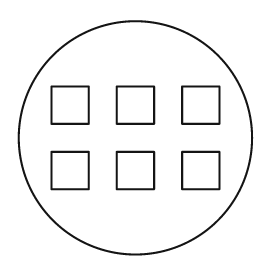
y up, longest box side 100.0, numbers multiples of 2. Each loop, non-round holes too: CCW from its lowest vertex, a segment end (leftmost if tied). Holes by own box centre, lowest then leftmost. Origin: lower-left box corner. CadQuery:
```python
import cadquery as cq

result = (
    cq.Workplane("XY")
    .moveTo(50.0, 50.0)
    .circle(50.0)
    .moveTo(14.0, 28.0)
    .lineTo(30.0, 28.0)
    .lineTo(30.0, 44.0)
    .lineTo(14.0, 44.0)
    .close()
    .moveTo(42.0, 28.0)
    .lineTo(58.0, 28.0)
    .lineTo(58.0, 44.0)
    .lineTo(42.0, 44.0)
    .close()
    .moveTo(70.0, 28.0)
    .lineTo(86.0, 28.0)
    .lineTo(86.0, 44.0)
    .lineTo(70.0, 44.0)
    .close()
    .moveTo(14.0, 56.0)
    .lineTo(30.0, 56.0)
    .lineTo(30.0, 72.0)
    .lineTo(14.0, 72.0)
    .close()
    .moveTo(42.0, 56.0)
    .lineTo(58.0, 56.0)
    .lineTo(58.0, 72.0)
    .lineTo(42.0, 72.0)
    .close()
    .moveTo(70.0, 56.0)
    .lineTo(86.0, 56.0)
    .lineTo(86.0, 72.0)
    .lineTo(70.0, 72.0)
    .close()
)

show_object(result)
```